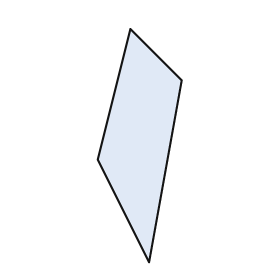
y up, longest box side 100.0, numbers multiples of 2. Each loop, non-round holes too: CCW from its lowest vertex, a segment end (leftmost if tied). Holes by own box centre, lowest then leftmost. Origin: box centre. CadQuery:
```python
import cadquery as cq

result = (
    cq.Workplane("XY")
    .moveTo(4.0, -50.0)
    .lineTo(18.0, 28.0)
    .lineTo(-4.0, 50.0)
    .lineTo(-18.0, -6.0)
    .close()
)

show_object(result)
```